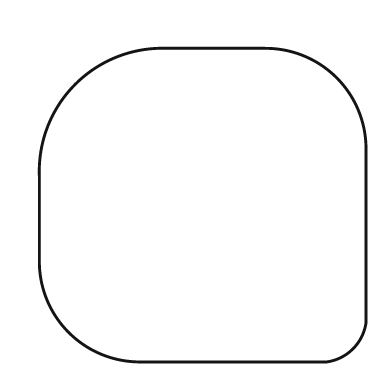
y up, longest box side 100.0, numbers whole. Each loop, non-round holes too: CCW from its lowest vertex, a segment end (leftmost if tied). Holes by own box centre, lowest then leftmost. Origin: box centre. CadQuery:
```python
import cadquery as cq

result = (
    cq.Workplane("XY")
    .moveTo(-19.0, -48.0)
    .lineTo(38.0, -48.0)
    .threePointArc((46.0, -44.0), (50.0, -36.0))
    .lineTo(50.0, 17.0)
    .threePointArc((41.0, 39.0), (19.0, 48.0))
    .lineTo(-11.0, 48.0)
    .threePointArc((-39.0, 37.0), (-50.0, 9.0))
    .lineTo(-50.0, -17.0)
    .threePointArc((-41.0, -39.0), (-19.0, -48.0))
    .close()
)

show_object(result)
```